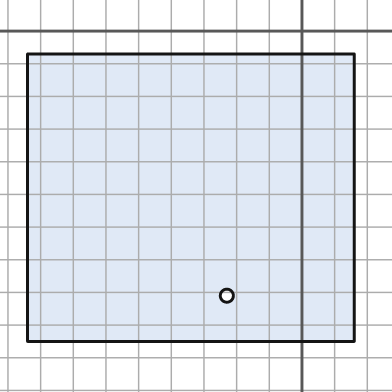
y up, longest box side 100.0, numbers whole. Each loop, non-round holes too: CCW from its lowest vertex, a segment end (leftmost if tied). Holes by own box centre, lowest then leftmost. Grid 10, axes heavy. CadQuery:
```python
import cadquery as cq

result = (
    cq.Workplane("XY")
    .moveTo(-84.0, -95.0)
    .lineTo(16.0, -95.0)
    .lineTo(16.0, -7.0)
    .lineTo(-84.0, -7.0)
    .close()
    .moveTo(-23.0, -81.0)
    .circle(2.0)
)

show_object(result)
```